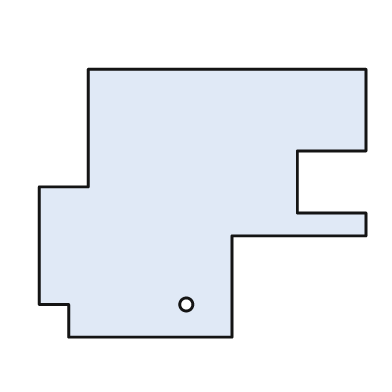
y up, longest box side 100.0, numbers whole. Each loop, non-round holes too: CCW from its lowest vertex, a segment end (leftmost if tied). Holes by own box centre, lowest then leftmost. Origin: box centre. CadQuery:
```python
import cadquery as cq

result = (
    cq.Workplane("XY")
    .moveTo(-41.0, -41.0)
    .lineTo(9.0, -41.0)
    .lineTo(9.0, -10.0)
    .lineTo(50.0, -10.0)
    .lineTo(50.0, -3.0)
    .lineTo(29.0, -3.0)
    .lineTo(29.0, 16.0)
    .lineTo(50.0, 16.0)
    .lineTo(50.0, 41.0)
    .lineTo(-35.0, 41.0)
    .lineTo(-35.0, 5.0)
    .lineTo(-50.0, 5.0)
    .lineTo(-50.0, -31.0)
    .lineTo(-41.0, -31.0)
    .close()
    .moveTo(-5.0, -31.0)
    .circle(2.0)
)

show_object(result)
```